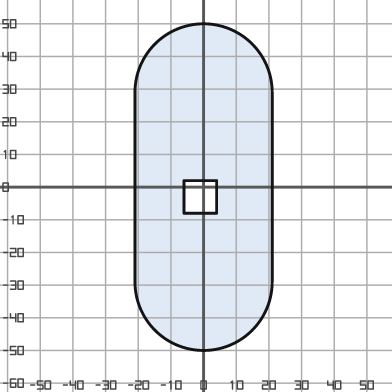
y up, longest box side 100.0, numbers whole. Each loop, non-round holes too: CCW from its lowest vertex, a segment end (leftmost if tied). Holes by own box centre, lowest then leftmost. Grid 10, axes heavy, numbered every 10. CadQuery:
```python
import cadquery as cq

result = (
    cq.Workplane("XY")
    .moveTo(-21.0, -29.0)
    .threePointArc((0.0, -50.0), (21.0, -29.0))
    .lineTo(21.0, 29.0)
    .threePointArc((0.0, 50.0), (-21.0, 29.0))
    .close()
    .moveTo(-6.0, -8.0)
    .lineTo(4.0, -8.0)
    .lineTo(4.0, 2.0)
    .lineTo(-6.0, 2.0)
    .close()
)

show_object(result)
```